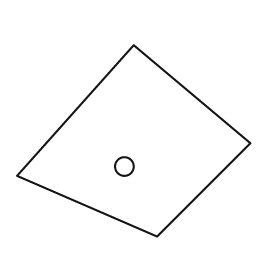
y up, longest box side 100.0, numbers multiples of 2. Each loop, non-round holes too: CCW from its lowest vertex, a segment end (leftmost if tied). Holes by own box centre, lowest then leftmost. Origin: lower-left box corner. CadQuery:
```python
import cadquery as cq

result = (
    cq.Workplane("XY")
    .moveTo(60.0, 0.0)
    .lineTo(100.0, 40.0)
    .lineTo(50.0, 82.0)
    .lineTo(0.0, 26.0)
    .close()
    .moveTo(46.0, 30.0)
    .circle(4.0)
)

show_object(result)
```